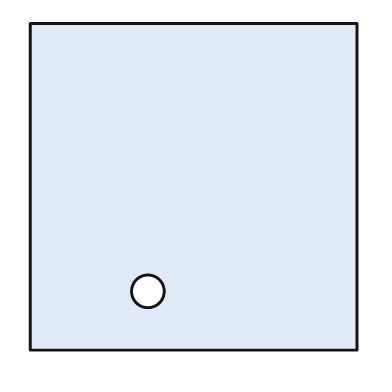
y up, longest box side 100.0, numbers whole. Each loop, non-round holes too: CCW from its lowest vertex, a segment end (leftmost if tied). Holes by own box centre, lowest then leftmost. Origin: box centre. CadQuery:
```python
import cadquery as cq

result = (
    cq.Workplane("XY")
    .moveTo(-50.0, -50.0)
    .lineTo(50.0, -50.0)
    .lineTo(50.0, 50.0)
    .lineTo(-50.0, 50.0)
    .close()
    .moveTo(-14.0, -32.0)
    .circle(5.0)
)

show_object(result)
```